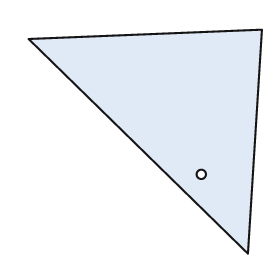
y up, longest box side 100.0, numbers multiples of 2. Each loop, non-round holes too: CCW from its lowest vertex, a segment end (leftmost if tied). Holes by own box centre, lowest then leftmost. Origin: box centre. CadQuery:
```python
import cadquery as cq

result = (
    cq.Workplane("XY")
    .moveTo(44.0, -48.0)
    .lineTo(50.0, 48.0)
    .lineTo(-50.0, 44.0)
    .close()
    .moveTo(24.0, -14.0)
    .circle(2.0)
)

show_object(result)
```